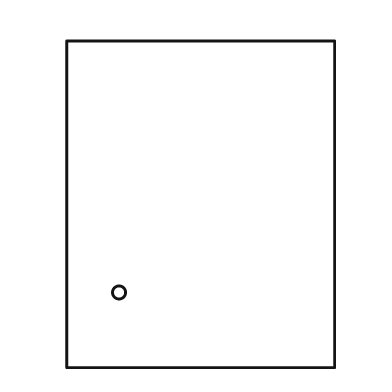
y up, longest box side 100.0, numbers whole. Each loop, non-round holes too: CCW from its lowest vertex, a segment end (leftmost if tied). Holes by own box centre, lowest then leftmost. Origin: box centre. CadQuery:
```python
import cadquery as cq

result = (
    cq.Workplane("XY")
    .moveTo(-41.0, -50.0)
    .lineTo(41.0, -50.0)
    .lineTo(41.0, 50.0)
    .lineTo(-41.0, 50.0)
    .close()
    .moveTo(-25.0, -27.0)
    .circle(2.0)
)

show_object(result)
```